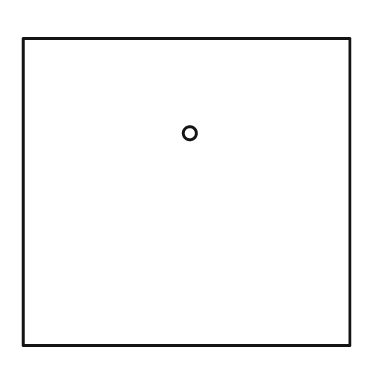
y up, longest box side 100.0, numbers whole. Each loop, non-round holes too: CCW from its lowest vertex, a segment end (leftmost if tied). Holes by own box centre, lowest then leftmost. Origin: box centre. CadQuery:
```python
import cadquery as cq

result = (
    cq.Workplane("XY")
    .moveTo(-50.0, -47.0)
    .lineTo(50.0, -47.0)
    .lineTo(50.0, 47.0)
    .lineTo(-50.0, 47.0)
    .close()
    .moveTo(1.0, 18.0)
    .circle(2.0)
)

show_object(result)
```